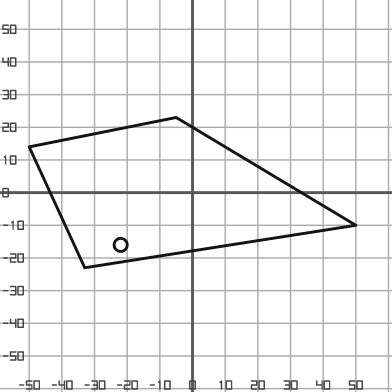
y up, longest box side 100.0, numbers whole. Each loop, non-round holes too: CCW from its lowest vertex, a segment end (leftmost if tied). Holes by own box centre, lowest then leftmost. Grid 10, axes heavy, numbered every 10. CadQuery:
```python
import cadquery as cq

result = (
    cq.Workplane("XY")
    .moveTo(-33.0, -23.0)
    .lineTo(50.0, -10.0)
    .lineTo(-5.0, 23.0)
    .lineTo(-50.0, 14.0)
    .close()
    .moveTo(-22.0, -16.0)
    .circle(2.0)
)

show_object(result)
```